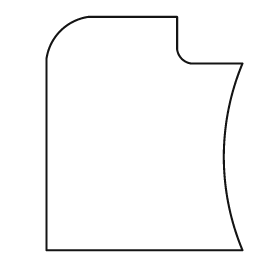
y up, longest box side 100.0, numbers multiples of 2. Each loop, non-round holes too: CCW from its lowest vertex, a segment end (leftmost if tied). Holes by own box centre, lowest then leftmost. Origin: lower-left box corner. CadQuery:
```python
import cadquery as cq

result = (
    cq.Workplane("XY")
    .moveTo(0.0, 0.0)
    .lineTo(84.0, 0.0)
    .threePointArc((76.0, 40.0), (84.0, 80.0))
    .lineTo(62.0, 80.0)
    .threePointArc((58.0, 82.0), (56.0, 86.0))
    .lineTo(56.0, 100.0)
    .lineTo(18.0, 100.0)
    .threePointArc((6.0, 94.0), (0.0, 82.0))
    .close()
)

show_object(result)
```